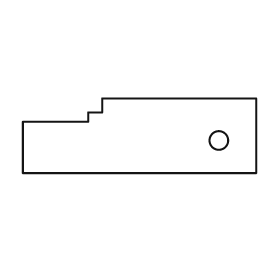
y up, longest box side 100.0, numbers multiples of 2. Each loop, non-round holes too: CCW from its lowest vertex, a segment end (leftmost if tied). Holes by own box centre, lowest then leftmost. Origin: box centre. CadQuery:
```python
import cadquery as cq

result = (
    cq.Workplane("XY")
    .moveTo(-50.0, -16.0)
    .lineTo(50.0, -16.0)
    .lineTo(50.0, 16.0)
    .lineTo(-16.0, 16.0)
    .lineTo(-16.0, 10.0)
    .lineTo(-22.0, 10.0)
    .lineTo(-22.0, 6.0)
    .lineTo(-50.0, 6.0)
    .close()
    .moveTo(34.0, -2.0)
    .circle(4.0)
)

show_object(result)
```